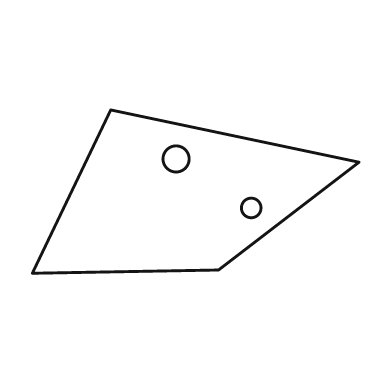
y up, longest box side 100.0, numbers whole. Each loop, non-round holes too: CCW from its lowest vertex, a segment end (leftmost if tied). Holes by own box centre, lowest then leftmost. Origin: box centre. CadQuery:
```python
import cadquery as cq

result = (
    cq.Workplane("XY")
    .moveTo(-50.0, -25.0)
    .lineTo(7.0, -24.0)
    .lineTo(50.0, 9.0)
    .lineTo(-26.0, 25.0)
    .close()
    .moveTo(17.0, -5.0)
    .circle(3.0)
    .moveTo(-6.0, 10.0)
    .circle(4.0)
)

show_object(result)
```